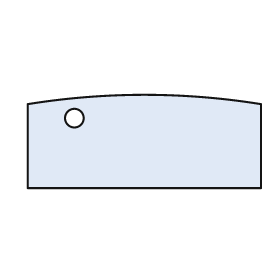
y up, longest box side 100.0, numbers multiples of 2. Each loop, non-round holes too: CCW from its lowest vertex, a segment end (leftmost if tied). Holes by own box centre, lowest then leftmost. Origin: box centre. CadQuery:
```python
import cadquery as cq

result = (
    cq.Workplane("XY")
    .moveTo(-50.0, -20.0)
    .lineTo(50.0, -20.0)
    .lineTo(50.0, 16.0)
    .threePointArc((0.0, 20.0), (-50.0, 16.0))
    .close()
    .moveTo(-30.0, 10.0)
    .circle(4.0)
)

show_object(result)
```